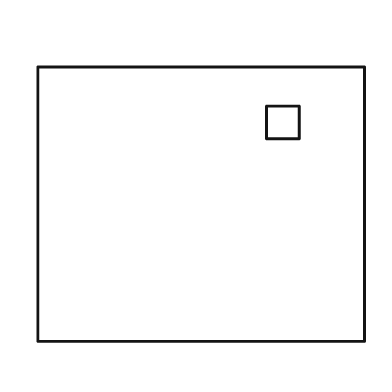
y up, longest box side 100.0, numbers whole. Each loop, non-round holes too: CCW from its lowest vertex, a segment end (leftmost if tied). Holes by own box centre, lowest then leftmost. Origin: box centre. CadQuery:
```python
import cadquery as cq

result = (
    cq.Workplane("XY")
    .moveTo(-50.0, -42.0)
    .lineTo(50.0, -42.0)
    .lineTo(50.0, 42.0)
    .lineTo(-50.0, 42.0)
    .close()
    .moveTo(20.0, 20.0)
    .lineTo(30.0, 20.0)
    .lineTo(30.0, 30.0)
    .lineTo(20.0, 30.0)
    .close()
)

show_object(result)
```